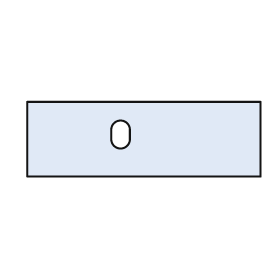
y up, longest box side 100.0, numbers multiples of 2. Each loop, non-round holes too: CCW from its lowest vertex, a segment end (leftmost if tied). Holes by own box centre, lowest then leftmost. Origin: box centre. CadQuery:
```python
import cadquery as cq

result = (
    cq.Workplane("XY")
    .moveTo(-50.0, -16.0)
    .lineTo(50.0, -16.0)
    .lineTo(50.0, 16.0)
    .lineTo(-50.0, 16.0)
    .close()
    .moveTo(-14.0, 0.0)
    .threePointArc((-10.0, -4.0), (-6.0, 0.0))
    .lineTo(-6.0, 4.0)
    .threePointArc((-10.0, 8.0), (-14.0, 4.0))
    .close()
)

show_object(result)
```